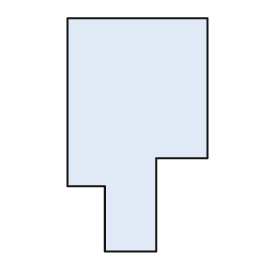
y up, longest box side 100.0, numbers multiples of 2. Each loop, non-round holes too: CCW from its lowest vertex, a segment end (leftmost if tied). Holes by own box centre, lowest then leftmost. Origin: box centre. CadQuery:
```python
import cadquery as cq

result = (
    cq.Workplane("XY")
    .moveTo(-14.0, -50.0)
    .lineTo(8.0, -50.0)
    .lineTo(8.0, -10.0)
    .lineTo(30.0, -10.0)
    .lineTo(30.0, 50.0)
    .lineTo(-30.0, 50.0)
    .lineTo(-30.0, -22.0)
    .lineTo(-14.0, -22.0)
    .close()
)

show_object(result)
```